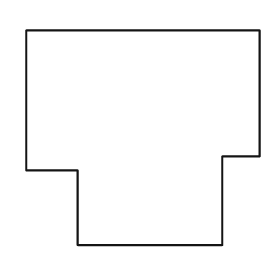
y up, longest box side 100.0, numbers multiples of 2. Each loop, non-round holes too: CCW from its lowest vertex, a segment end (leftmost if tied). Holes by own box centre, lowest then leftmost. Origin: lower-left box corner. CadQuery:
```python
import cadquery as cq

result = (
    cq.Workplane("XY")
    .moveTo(22.0, 0.0)
    .lineTo(84.0, 0.0)
    .lineTo(84.0, 38.0)
    .lineTo(100.0, 38.0)
    .lineTo(100.0, 92.0)
    .lineTo(0.0, 92.0)
    .lineTo(0.0, 32.0)
    .lineTo(22.0, 32.0)
    .close()
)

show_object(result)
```